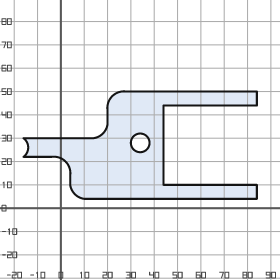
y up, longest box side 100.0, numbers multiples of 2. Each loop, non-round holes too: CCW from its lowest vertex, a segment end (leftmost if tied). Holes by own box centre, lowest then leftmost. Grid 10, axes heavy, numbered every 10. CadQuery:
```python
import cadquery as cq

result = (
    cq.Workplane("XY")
    .moveTo(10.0, 4.0)
    .lineTo(84.0, 4.0)
    .lineTo(84.0, 10.0)
    .lineTo(44.0, 10.0)
    .lineTo(44.0, 44.0)
    .lineTo(84.0, 44.0)
    .lineTo(84.0, 50.0)
    .lineTo(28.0, 50.0)
    .threePointArc((22.0, 48.0), (20.0, 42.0))
    .lineTo(20.0, 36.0)
    .threePointArc((18.0, 32.0), (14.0, 30.0))
    .lineTo(-16.0, 30.0)
    .threePointArc((-14.0, 26.0), (-16.0, 22.0))
    .lineTo(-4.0, 22.0)
    .threePointArc((2.0, 20.0), (4.0, 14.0))
    .lineTo(4.0, 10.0)
    .threePointArc((6.0, 6.0), (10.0, 4.0))
    .close()
    .moveTo(34.0, 28.0)
    .circle(4.0)
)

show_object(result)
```